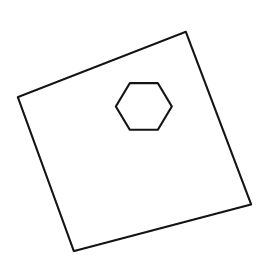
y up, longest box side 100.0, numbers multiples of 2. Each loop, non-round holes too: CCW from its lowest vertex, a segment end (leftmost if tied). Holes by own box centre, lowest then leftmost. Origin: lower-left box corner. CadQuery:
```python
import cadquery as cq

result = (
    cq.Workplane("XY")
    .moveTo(24.0, 0.0)
    .lineTo(100.0, 20.0)
    .lineTo(72.0, 94.0)
    .lineTo(0.0, 66.0)
    .close()
    .moveTo(48.0, 52.0)
    .lineTo(60.0, 52.0)
    .lineTo(66.0, 62.0)
    .lineTo(60.0, 72.0)
    .lineTo(48.0, 72.0)
    .lineTo(42.0, 62.0)
    .close()
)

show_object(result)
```